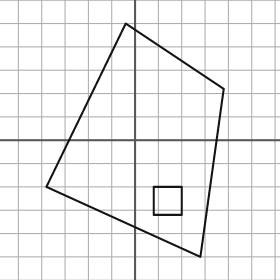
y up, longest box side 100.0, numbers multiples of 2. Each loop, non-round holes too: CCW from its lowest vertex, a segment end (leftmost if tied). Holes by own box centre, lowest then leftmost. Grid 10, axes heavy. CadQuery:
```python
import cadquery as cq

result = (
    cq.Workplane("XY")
    .moveTo(28.0, -50.0)
    .lineTo(38.0, 22.0)
    .lineTo(-4.0, 50.0)
    .lineTo(-38.0, -20.0)
    .close()
    .moveTo(8.0, -32.0)
    .lineTo(20.0, -32.0)
    .lineTo(20.0, -20.0)
    .lineTo(8.0, -20.0)
    .close()
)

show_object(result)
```